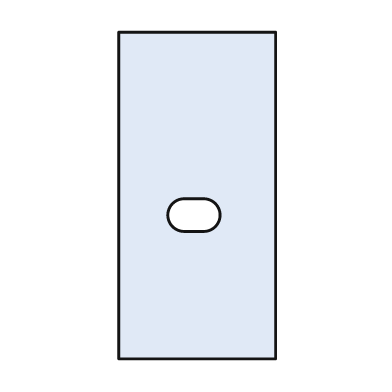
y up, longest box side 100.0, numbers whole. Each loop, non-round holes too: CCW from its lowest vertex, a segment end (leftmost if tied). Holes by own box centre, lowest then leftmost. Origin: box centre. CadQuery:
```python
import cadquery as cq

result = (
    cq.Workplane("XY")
    .moveTo(-24.0, -50.0)
    .lineTo(24.0, -50.0)
    .lineTo(24.0, 50.0)
    .lineTo(-24.0, 50.0)
    .close()
    .moveTo(-4.0, -11.0)
    .lineTo(2.0, -11.0)
    .threePointArc((7.0, -6.0), (2.0, -1.0))
    .lineTo(-4.0, -1.0)
    .threePointArc((-9.0, -6.0), (-4.0, -11.0))
    .close()
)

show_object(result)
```